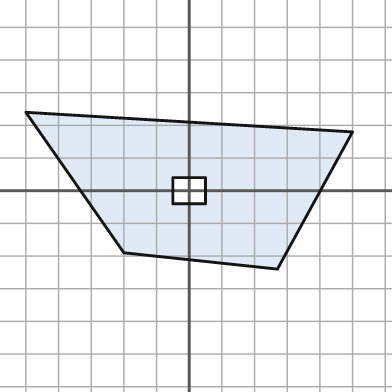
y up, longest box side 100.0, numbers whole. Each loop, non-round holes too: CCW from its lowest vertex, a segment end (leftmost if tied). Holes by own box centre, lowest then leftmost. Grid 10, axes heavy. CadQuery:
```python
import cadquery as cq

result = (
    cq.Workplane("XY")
    .moveTo(27.0, -24.0)
    .lineTo(50.0, 18.0)
    .lineTo(-50.0, 24.0)
    .lineTo(-20.0, -19.0)
    .close()
    .moveTo(-5.0, -4.0)
    .lineTo(5.0, -4.0)
    .lineTo(5.0, 4.0)
    .lineTo(-5.0, 4.0)
    .close()
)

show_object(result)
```